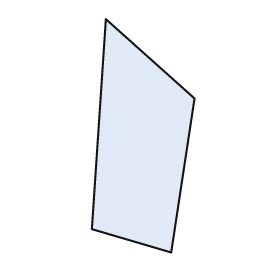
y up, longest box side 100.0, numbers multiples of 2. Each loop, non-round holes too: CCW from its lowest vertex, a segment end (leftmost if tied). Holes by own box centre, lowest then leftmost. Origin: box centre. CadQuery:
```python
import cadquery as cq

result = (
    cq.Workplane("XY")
    .moveTo(12.0, -50.0)
    .lineTo(22.0, 16.0)
    .lineTo(-16.0, 50.0)
    .lineTo(-22.0, -40.0)
    .close()
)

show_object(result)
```